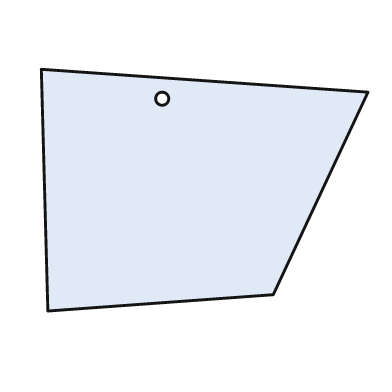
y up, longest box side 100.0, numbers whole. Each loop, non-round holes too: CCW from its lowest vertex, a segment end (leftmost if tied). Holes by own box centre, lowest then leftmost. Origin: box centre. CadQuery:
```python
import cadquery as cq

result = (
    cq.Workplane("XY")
    .moveTo(-48.0, -37.0)
    .lineTo(21.0, -32.0)
    .lineTo(50.0, 30.0)
    .lineTo(-50.0, 37.0)
    .close()
    .moveTo(-13.0, 28.0)
    .circle(2.0)
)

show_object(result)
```